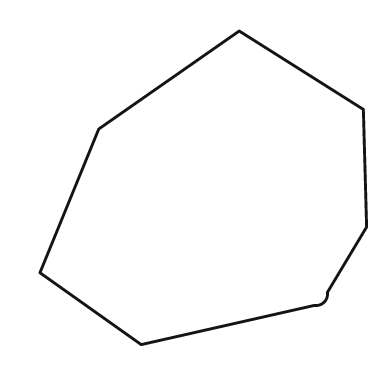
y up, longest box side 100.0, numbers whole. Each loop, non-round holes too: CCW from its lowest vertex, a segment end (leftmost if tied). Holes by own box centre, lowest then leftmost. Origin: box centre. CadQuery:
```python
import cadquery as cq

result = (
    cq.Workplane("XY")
    .moveTo(-19.0, -48.0)
    .lineTo(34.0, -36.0)
    .threePointArc((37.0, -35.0), (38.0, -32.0))
    .lineTo(50.0, -12.0)
    .lineTo(49.0, 24.0)
    .lineTo(11.0, 48.0)
    .lineTo(-32.0, 18.0)
    .lineTo(-50.0, -26.0)
    .close()
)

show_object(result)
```